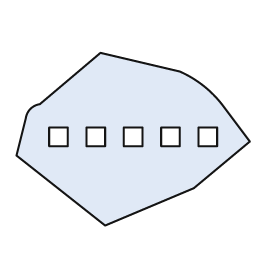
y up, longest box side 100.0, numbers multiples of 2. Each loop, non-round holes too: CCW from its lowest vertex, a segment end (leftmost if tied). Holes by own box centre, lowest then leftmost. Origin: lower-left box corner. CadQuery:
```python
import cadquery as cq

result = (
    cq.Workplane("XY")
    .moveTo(38.0, 0.0)
    .lineTo(76.0, 16.0)
    .lineTo(100.0, 36.0)
    .lineTo(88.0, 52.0)
    .threePointArc((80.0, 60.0), (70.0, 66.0))
    .lineTo(36.0, 74.0)
    .lineTo(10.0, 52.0)
    .threePointArc((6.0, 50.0), (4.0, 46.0))
    .lineTo(0.0, 30.0)
    .close()
    .moveTo(14.0, 34.0)
    .lineTo(22.0, 34.0)
    .lineTo(22.0, 42.0)
    .lineTo(14.0, 42.0)
    .close()
    .moveTo(30.0, 34.0)
    .lineTo(38.0, 34.0)
    .lineTo(38.0, 42.0)
    .lineTo(30.0, 42.0)
    .close()
    .moveTo(46.0, 34.0)
    .lineTo(54.0, 34.0)
    .lineTo(54.0, 42.0)
    .lineTo(46.0, 42.0)
    .close()
    .moveTo(62.0, 34.0)
    .lineTo(70.0, 34.0)
    .lineTo(70.0, 42.0)
    .lineTo(62.0, 42.0)
    .close()
    .moveTo(78.0, 34.0)
    .lineTo(86.0, 34.0)
    .lineTo(86.0, 42.0)
    .lineTo(78.0, 42.0)
    .close()
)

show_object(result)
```